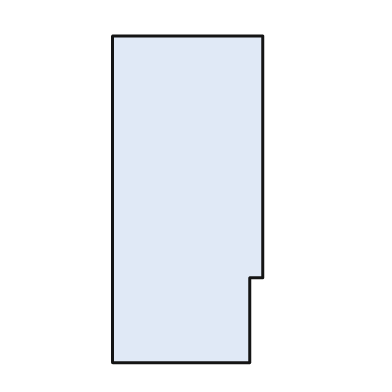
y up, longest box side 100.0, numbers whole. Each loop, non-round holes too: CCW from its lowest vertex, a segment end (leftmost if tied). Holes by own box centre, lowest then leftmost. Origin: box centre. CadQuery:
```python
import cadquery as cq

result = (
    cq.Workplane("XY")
    .moveTo(-23.0, -50.0)
    .lineTo(19.0, -50.0)
    .lineTo(19.0, -24.0)
    .lineTo(23.0, -24.0)
    .lineTo(23.0, 50.0)
    .lineTo(-23.0, 50.0)
    .close()
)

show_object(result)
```